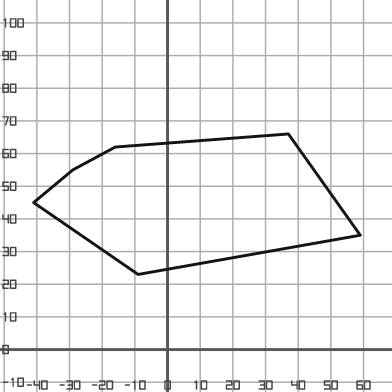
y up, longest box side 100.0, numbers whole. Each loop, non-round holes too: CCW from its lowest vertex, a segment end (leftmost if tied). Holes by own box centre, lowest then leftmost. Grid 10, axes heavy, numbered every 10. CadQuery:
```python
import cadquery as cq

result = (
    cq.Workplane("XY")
    .moveTo(-9.0, 23.0)
    .lineTo(59.0, 35.0)
    .lineTo(37.0, 66.0)
    .lineTo(-16.0, 62.0)
    .lineTo(-29.0, 55.0)
    .lineTo(-41.0, 45.0)
    .close()
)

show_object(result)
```